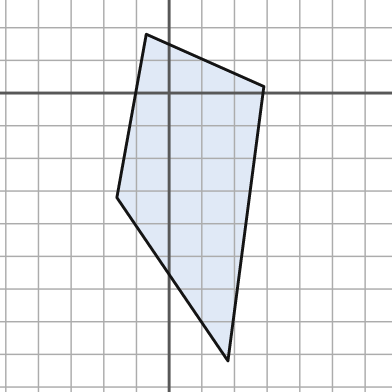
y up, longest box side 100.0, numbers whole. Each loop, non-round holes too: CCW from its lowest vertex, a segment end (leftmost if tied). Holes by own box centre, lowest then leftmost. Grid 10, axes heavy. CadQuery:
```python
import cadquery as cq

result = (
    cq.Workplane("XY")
    .moveTo(18.0, -82.0)
    .lineTo(29.0, 2.0)
    .lineTo(-7.0, 18.0)
    .lineTo(-16.0, -32.0)
    .close()
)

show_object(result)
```